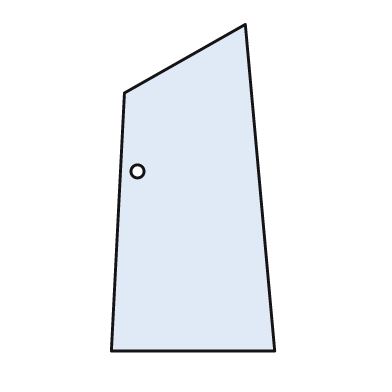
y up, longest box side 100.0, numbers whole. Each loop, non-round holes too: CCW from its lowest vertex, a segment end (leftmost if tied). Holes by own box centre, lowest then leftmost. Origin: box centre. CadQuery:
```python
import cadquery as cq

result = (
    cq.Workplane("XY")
    .moveTo(-25.0, -50.0)
    .lineTo(25.0, -50.0)
    .lineTo(16.0, 50.0)
    .lineTo(-21.0, 29.0)
    .close()
    .moveTo(-17.0, 5.0)
    .circle(2.0)
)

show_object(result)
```